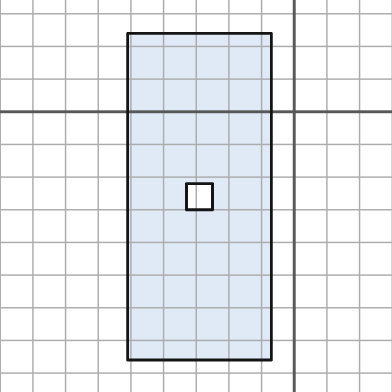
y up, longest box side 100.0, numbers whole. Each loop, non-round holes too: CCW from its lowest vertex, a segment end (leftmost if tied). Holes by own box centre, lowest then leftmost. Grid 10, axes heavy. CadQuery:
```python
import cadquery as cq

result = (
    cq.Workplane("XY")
    .moveTo(-51.0, -76.0)
    .lineTo(-7.0, -76.0)
    .lineTo(-7.0, 24.0)
    .lineTo(-51.0, 24.0)
    .close()
    .moveTo(-33.0, -30.0)
    .lineTo(-25.0, -30.0)
    .lineTo(-25.0, -22.0)
    .lineTo(-33.0, -22.0)
    .close()
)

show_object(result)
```